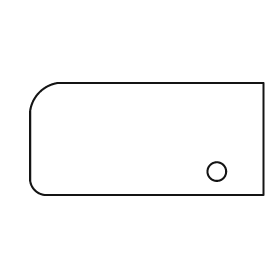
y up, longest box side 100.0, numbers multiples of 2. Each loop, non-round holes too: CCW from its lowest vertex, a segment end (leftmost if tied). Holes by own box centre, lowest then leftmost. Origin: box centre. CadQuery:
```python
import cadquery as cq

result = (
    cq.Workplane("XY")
    .moveTo(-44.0, -24.0)
    .lineTo(50.0, -24.0)
    .lineTo(50.0, 24.0)
    .lineTo(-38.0, 24.0)
    .threePointArc((-46.0, 20.0), (-50.0, 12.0))
    .lineTo(-50.0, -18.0)
    .threePointArc((-48.0, -22.0), (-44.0, -24.0))
    .close()
    .moveTo(30.0, -14.0)
    .circle(4.0)
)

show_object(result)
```